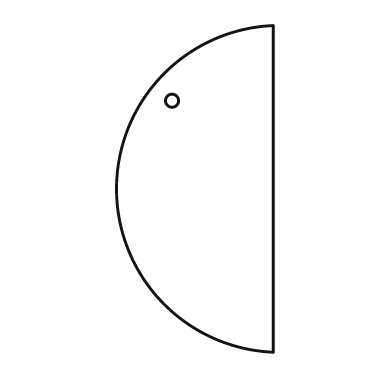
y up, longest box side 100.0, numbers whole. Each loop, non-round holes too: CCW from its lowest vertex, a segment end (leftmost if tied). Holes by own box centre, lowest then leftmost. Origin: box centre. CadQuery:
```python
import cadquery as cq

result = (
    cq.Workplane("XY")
    .moveTo(24.0, -50.0)
    .lineTo(24.0, 50.0)
    .threePointArc((-24.0, 0.0), (24.0, -50.0))
    .close()
    .moveTo(-7.0, 27.0)
    .circle(2.0)
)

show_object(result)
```